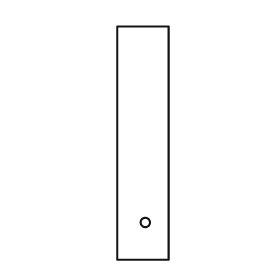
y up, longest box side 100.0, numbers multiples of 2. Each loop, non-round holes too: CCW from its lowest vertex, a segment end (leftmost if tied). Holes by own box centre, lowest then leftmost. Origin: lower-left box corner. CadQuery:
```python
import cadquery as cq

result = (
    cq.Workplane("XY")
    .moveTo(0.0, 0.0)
    .lineTo(22.0, 0.0)
    .lineTo(22.0, 100.0)
    .lineTo(0.0, 100.0)
    .close()
    .moveTo(12.0, 16.0)
    .circle(2.0)
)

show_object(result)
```